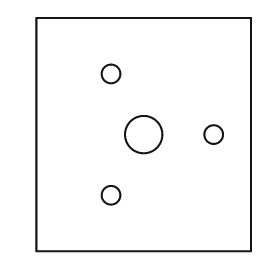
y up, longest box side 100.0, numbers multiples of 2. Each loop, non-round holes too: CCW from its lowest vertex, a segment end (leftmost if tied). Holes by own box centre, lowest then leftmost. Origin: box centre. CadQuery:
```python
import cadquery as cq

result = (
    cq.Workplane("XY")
    .moveTo(-46.0, -50.0)
    .lineTo(46.0, -50.0)
    .lineTo(46.0, 50.0)
    .lineTo(-46.0, 50.0)
    .close()
    .moveTo(-14.0, -26.0)
    .circle(4.0)
    .moveTo(0.0, 0.0)
    .circle(8.0)
    .moveTo(30.0, 0.0)
    .circle(4.0)
    .moveTo(-14.0, 26.0)
    .circle(4.0)
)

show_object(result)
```